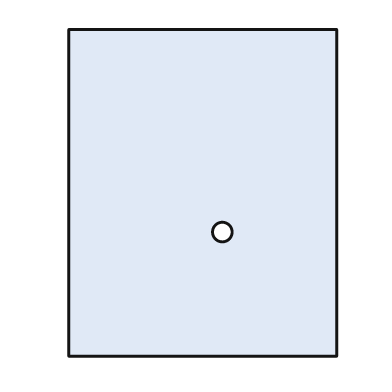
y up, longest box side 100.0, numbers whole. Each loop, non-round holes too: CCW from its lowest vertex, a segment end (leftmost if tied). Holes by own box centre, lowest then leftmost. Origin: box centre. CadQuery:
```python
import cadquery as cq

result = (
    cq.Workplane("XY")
    .moveTo(-41.0, -50.0)
    .lineTo(41.0, -50.0)
    .lineTo(41.0, 50.0)
    .lineTo(-41.0, 50.0)
    .close()
    .moveTo(6.0, -12.0)
    .circle(3.0)
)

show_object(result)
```